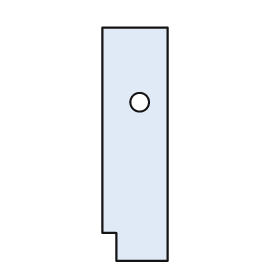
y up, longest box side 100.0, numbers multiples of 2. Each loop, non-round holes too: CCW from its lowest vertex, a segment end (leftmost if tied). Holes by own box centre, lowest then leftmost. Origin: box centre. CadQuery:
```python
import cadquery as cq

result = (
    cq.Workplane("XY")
    .moveTo(-8.0, -50.0)
    .lineTo(14.0, -50.0)
    .lineTo(14.0, 50.0)
    .lineTo(-14.0, 50.0)
    .lineTo(-14.0, -38.0)
    .lineTo(-8.0, -38.0)
    .close()
    .moveTo(2.0, 18.0)
    .circle(4.0)
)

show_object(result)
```